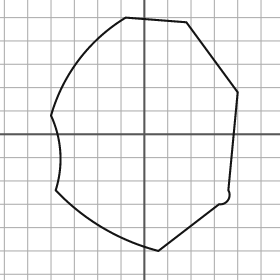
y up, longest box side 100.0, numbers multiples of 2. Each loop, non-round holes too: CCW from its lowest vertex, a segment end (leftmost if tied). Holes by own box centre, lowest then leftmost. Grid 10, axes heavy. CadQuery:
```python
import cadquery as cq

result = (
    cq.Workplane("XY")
    .moveTo(6.0, -50.0)
    .lineTo(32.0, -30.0)
    .threePointArc((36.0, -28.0), (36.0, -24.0))
    .lineTo(40.0, 18.0)
    .lineTo(18.0, 48.0)
    .lineTo(-8.0, 50.0)
    .threePointArc((-28.0, 32.0), (-40.0, 8.0))
    .threePointArc((-36.0, -8.0), (-38.0, -24.0))
    .threePointArc((-18.0, -40.0), (6.0, -50.0))
    .close()
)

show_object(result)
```